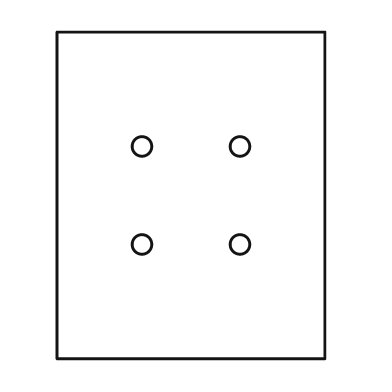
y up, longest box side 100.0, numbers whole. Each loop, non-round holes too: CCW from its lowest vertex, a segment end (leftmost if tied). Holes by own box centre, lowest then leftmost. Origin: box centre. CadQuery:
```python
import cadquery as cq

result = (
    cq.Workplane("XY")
    .moveTo(-41.0, -50.0)
    .lineTo(41.0, -50.0)
    .lineTo(41.0, 50.0)
    .lineTo(-41.0, 50.0)
    .close()
    .moveTo(-15.0, -15.0)
    .circle(3.0)
    .moveTo(15.0, -15.0)
    .circle(3.0)
    .moveTo(-15.0, 15.0)
    .circle(3.0)
    .moveTo(15.0, 15.0)
    .circle(3.0)
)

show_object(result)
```